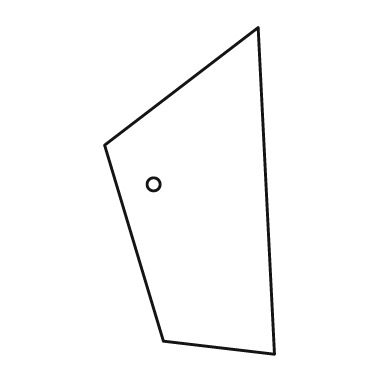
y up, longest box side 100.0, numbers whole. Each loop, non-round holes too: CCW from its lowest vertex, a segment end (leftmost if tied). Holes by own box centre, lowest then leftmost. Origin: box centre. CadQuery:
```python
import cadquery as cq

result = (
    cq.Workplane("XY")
    .moveTo(26.0, -50.0)
    .lineTo(21.0, 50.0)
    .lineTo(-26.0, 14.0)
    .lineTo(-8.0, -46.0)
    .close()
    .moveTo(-11.0, 2.0)
    .circle(2.0)
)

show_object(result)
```